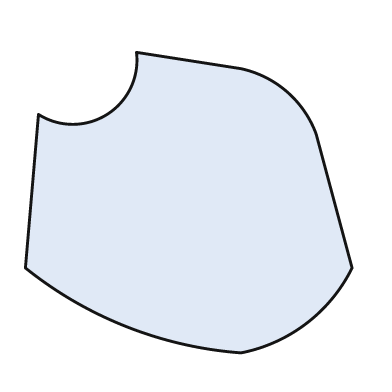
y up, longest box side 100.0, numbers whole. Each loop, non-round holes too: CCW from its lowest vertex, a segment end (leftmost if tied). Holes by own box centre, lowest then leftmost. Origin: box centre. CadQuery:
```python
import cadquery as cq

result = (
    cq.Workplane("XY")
    .moveTo(16.0, -46.0)
    .threePointArc((36.0, -37.0), (50.0, -20.0))
    .lineTo(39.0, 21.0)
    .threePointArc((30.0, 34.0), (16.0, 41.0))
    .lineTo(-16.0, 46.0)
    .threePointArc((-25.0, 27.0), (-46.0, 27.0))
    .lineTo(-50.0, -20.0)
    .threePointArc((-19.0, -38.0), (16.0, -46.0))
    .close()
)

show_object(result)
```